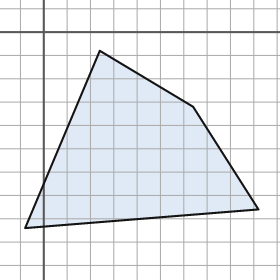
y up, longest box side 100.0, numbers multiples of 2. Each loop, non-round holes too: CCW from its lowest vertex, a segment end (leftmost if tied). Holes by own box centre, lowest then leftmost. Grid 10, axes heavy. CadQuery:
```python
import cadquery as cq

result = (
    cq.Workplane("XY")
    .moveTo(-8.0, -84.0)
    .lineTo(92.0, -76.0)
    .lineTo(64.0, -32.0)
    .lineTo(24.0, -8.0)
    .close()
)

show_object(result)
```